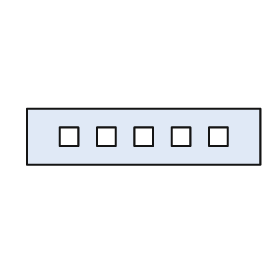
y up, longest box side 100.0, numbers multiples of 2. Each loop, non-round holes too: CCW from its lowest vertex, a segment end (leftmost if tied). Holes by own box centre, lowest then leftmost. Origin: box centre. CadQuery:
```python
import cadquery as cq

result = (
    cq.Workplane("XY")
    .moveTo(-50.0, -12.0)
    .lineTo(50.0, -12.0)
    .lineTo(50.0, 12.0)
    .lineTo(-50.0, 12.0)
    .close()
    .moveTo(-36.0, -4.0)
    .lineTo(-28.0, -4.0)
    .lineTo(-28.0, 4.0)
    .lineTo(-36.0, 4.0)
    .close()
    .moveTo(-20.0, -4.0)
    .lineTo(-12.0, -4.0)
    .lineTo(-12.0, 4.0)
    .lineTo(-20.0, 4.0)
    .close()
    .moveTo(-4.0, -4.0)
    .lineTo(4.0, -4.0)
    .lineTo(4.0, 4.0)
    .lineTo(-4.0, 4.0)
    .close()
    .moveTo(12.0, -4.0)
    .lineTo(20.0, -4.0)
    .lineTo(20.0, 4.0)
    .lineTo(12.0, 4.0)
    .close()
    .moveTo(28.0, -4.0)
    .lineTo(36.0, -4.0)
    .lineTo(36.0, 4.0)
    .lineTo(28.0, 4.0)
    .close()
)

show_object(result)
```